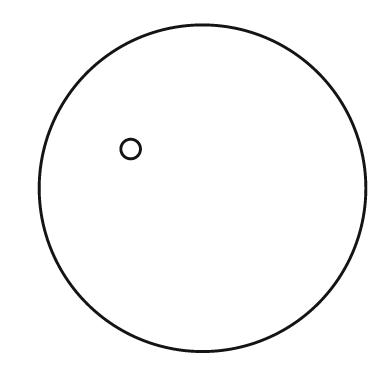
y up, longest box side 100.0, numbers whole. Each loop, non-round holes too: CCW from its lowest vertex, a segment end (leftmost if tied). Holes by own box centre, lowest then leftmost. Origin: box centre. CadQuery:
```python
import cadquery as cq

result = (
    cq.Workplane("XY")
    .moveTo(0.0, 0.0)
    .circle(50.0)
    .moveTo(-22.0, 12.0)
    .circle(3.0)
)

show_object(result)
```